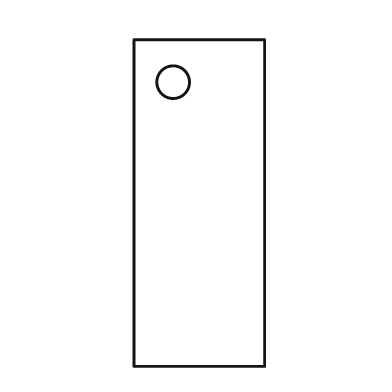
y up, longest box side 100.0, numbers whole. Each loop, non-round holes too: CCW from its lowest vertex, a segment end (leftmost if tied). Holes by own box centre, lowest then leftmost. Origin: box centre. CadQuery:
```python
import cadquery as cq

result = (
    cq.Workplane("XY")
    .moveTo(-20.0, -50.0)
    .lineTo(20.0, -50.0)
    .lineTo(20.0, 50.0)
    .lineTo(-20.0, 50.0)
    .close()
    .moveTo(-8.0, 37.0)
    .circle(5.0)
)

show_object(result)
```